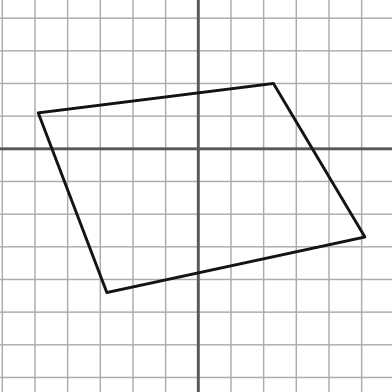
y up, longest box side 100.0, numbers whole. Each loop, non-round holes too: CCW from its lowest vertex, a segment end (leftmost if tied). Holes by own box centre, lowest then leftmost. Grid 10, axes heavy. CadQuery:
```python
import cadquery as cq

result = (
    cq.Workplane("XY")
    .moveTo(-28.0, -44.0)
    .lineTo(51.0, -27.0)
    .lineTo(23.0, 20.0)
    .lineTo(-49.0, 11.0)
    .close()
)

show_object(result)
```